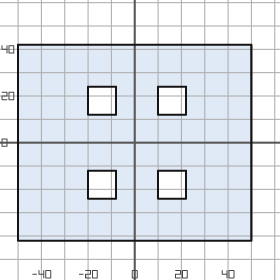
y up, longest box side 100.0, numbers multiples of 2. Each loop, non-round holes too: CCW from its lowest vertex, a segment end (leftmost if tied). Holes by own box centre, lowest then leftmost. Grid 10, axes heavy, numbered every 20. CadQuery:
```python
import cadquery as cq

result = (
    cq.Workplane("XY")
    .moveTo(-50.0, -42.0)
    .lineTo(50.0, -42.0)
    .lineTo(50.0, 42.0)
    .lineTo(-50.0, 42.0)
    .close()
    .moveTo(-20.0, -24.0)
    .lineTo(-8.0, -24.0)
    .lineTo(-8.0, -12.0)
    .lineTo(-20.0, -12.0)
    .close()
    .moveTo(10.0, -24.0)
    .lineTo(22.0, -24.0)
    .lineTo(22.0, -12.0)
    .lineTo(10.0, -12.0)
    .close()
    .moveTo(-20.0, 12.0)
    .lineTo(-8.0, 12.0)
    .lineTo(-8.0, 24.0)
    .lineTo(-20.0, 24.0)
    .close()
    .moveTo(10.0, 12.0)
    .lineTo(22.0, 12.0)
    .lineTo(22.0, 24.0)
    .lineTo(10.0, 24.0)
    .close()
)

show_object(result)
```